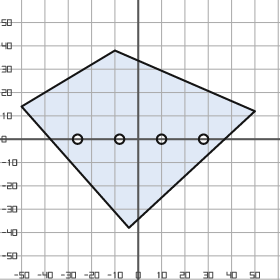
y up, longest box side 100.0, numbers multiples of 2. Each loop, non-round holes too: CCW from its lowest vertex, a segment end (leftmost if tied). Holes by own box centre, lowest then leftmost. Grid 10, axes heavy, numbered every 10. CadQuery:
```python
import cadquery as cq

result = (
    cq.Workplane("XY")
    .moveTo(-4.0, -38.0)
    .lineTo(50.0, 12.0)
    .lineTo(-10.0, 38.0)
    .lineTo(-50.0, 14.0)
    .close()
    .moveTo(-26.0, 0.0)
    .circle(2.0)
    .moveTo(-8.0, 0.0)
    .circle(2.0)
    .moveTo(10.0, 0.0)
    .circle(2.0)
    .moveTo(28.0, 0.0)
    .circle(2.0)
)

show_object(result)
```